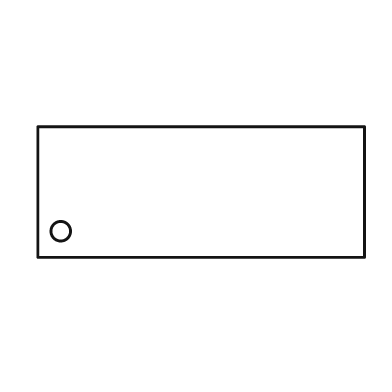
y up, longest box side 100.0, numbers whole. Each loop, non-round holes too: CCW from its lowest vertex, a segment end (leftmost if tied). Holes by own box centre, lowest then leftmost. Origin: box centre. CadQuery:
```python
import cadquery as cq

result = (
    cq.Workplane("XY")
    .moveTo(-50.0, -20.0)
    .lineTo(50.0, -20.0)
    .lineTo(50.0, 20.0)
    .lineTo(-50.0, 20.0)
    .close()
    .moveTo(-43.0, -12.0)
    .circle(3.0)
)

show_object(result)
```